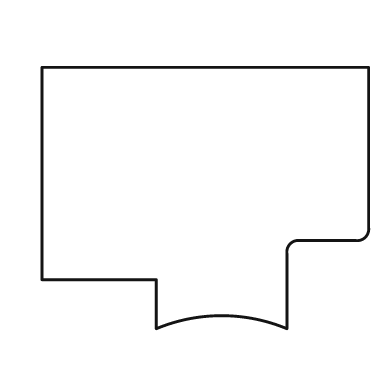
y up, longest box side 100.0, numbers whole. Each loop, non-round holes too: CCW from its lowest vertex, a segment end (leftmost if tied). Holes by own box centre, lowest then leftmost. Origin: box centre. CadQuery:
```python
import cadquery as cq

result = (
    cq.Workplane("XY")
    .moveTo(-15.0, -40.0)
    .threePointArc((5.0, -36.0), (25.0, -40.0))
    .lineTo(25.0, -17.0)
    .threePointArc((26.0, -14.0), (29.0, -13.0))
    .lineTo(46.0, -13.0)
    .threePointArc((49.0, -12.0), (50.0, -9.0))
    .lineTo(50.0, 40.0)
    .lineTo(-50.0, 40.0)
    .lineTo(-50.0, -25.0)
    .lineTo(-15.0, -25.0)
    .close()
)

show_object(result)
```